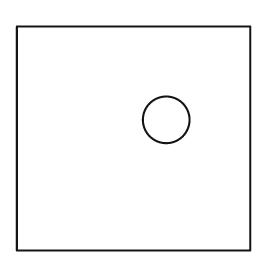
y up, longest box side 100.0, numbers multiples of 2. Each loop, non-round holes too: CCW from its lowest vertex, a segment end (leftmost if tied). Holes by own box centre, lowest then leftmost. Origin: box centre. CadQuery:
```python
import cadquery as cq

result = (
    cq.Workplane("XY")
    .moveTo(-50.0, -48.0)
    .lineTo(50.0, -48.0)
    .lineTo(50.0, 48.0)
    .lineTo(-50.0, 48.0)
    .close()
    .moveTo(14.0, 8.0)
    .circle(10.0)
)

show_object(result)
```